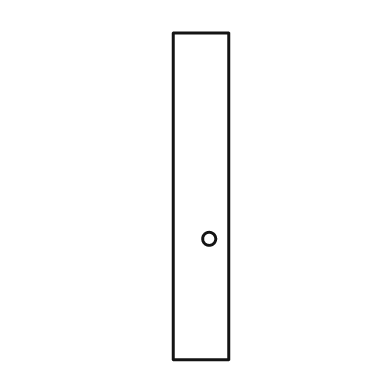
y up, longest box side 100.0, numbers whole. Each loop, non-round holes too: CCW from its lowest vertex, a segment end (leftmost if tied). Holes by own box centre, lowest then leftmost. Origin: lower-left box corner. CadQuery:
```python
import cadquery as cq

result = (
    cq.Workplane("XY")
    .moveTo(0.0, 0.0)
    .lineTo(17.0, 0.0)
    .lineTo(17.0, 100.0)
    .lineTo(0.0, 100.0)
    .close()
    .moveTo(11.0, 37.0)
    .circle(2.0)
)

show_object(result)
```